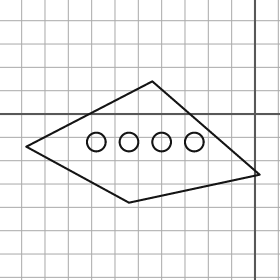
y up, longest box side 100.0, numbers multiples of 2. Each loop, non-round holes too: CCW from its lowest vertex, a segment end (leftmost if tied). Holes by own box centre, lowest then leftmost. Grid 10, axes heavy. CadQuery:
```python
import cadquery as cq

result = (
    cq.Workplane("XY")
    .moveTo(-54.0, -38.0)
    .lineTo(2.0, -26.0)
    .lineTo(-44.0, 14.0)
    .lineTo(-98.0, -14.0)
    .close()
    .moveTo(-68.0, -12.0)
    .circle(4.0)
    .moveTo(-54.0, -12.0)
    .circle(4.0)
    .moveTo(-40.0, -12.0)
    .circle(4.0)
    .moveTo(-26.0, -12.0)
    .circle(4.0)
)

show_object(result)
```